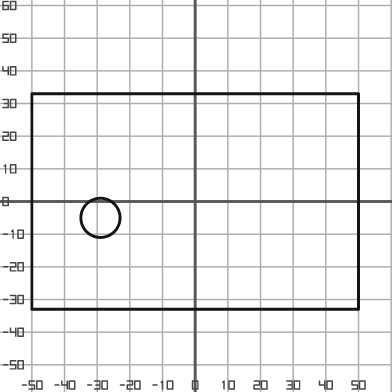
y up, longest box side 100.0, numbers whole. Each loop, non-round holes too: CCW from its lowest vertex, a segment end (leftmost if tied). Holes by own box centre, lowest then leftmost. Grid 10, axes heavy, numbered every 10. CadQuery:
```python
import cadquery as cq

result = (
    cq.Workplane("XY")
    .moveTo(-50.0, -33.0)
    .lineTo(50.0, -33.0)
    .lineTo(50.0, 33.0)
    .lineTo(-50.0, 33.0)
    .close()
    .moveTo(-29.0, -5.0)
    .circle(6.0)
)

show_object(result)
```